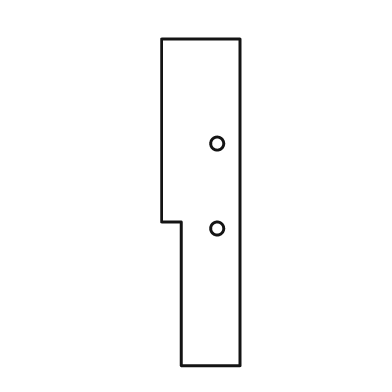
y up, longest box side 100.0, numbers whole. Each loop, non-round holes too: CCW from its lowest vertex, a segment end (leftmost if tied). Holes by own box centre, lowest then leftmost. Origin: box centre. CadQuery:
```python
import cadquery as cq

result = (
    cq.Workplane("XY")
    .moveTo(-6.0, -50.0)
    .lineTo(12.0, -50.0)
    .lineTo(12.0, 50.0)
    .lineTo(-12.0, 50.0)
    .lineTo(-12.0, -6.0)
    .lineTo(-6.0, -6.0)
    .close()
    .moveTo(5.0, -8.0)
    .circle(2.0)
    .moveTo(5.0, 18.0)
    .circle(2.0)
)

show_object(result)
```